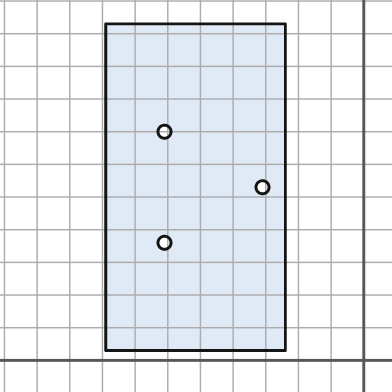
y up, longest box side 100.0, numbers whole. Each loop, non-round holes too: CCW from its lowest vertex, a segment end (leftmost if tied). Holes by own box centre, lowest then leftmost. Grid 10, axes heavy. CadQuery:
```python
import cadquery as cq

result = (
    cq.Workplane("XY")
    .moveTo(-79.0, 3.0)
    .lineTo(-24.0, 3.0)
    .lineTo(-24.0, 103.0)
    .lineTo(-79.0, 103.0)
    .close()
    .moveTo(-61.0, 36.0)
    .circle(2.0)
    .moveTo(-31.0, 53.0)
    .circle(2.0)
    .moveTo(-61.0, 70.0)
    .circle(2.0)
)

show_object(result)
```